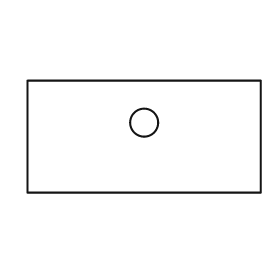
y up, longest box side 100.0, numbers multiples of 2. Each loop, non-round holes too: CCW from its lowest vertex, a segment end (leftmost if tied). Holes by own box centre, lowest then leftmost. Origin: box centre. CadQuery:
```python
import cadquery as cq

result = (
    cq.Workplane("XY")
    .moveTo(-50.0, -24.0)
    .lineTo(50.0, -24.0)
    .lineTo(50.0, 24.0)
    .lineTo(-50.0, 24.0)
    .close()
    .moveTo(0.0, 6.0)
    .circle(6.0)
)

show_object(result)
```